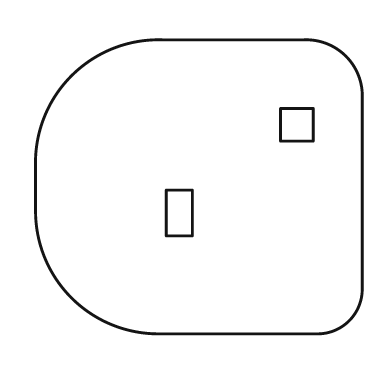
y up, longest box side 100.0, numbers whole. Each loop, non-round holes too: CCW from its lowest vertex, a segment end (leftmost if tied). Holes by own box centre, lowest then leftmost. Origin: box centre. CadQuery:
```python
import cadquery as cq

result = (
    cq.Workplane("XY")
    .moveTo(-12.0, -45.0)
    .lineTo(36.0, -45.0)
    .threePointArc((46.0, -41.0), (50.0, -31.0))
    .lineTo(50.0, 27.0)
    .threePointArc((45.0, 40.0), (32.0, 45.0))
    .lineTo(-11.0, 45.0)
    .threePointArc((-39.0, 34.0), (-50.0, 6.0))
    .lineTo(-50.0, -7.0)
    .threePointArc((-39.0, -34.0), (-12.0, -45.0))
    .close()
    .moveTo(-10.0, -15.0)
    .lineTo(-2.0, -15.0)
    .lineTo(-2.0, -1.0)
    .lineTo(-10.0, -1.0)
    .close()
    .moveTo(25.0, 14.0)
    .lineTo(35.0, 14.0)
    .lineTo(35.0, 24.0)
    .lineTo(25.0, 24.0)
    .close()
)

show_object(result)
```